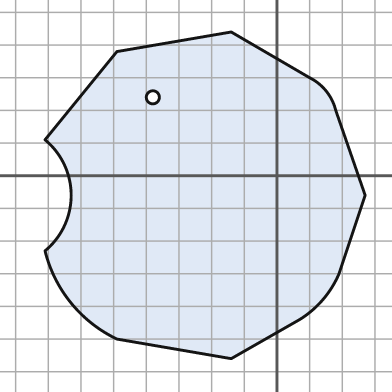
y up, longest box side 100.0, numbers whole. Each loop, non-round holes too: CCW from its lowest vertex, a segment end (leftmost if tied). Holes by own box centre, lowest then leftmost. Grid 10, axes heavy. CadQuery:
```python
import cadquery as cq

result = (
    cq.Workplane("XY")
    .moveTo(-14.0, -56.0)
    .lineTo(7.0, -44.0)
    .threePointArc((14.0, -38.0), (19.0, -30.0))
    .lineTo(27.0, -6.0)
    .lineTo(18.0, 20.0)
    .threePointArc((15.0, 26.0), (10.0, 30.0))
    .lineTo(-14.0, 44.0)
    .lineTo(-49.0, 38.0)
    .lineTo(-71.0, 11.0)
    .threePointArc((-63.0, -6.0), (-71.0, -23.0))
    .threePointArc((-63.0, -39.0), (-49.0, -50.0))
    .close()
    .moveTo(-38.0, 24.0)
    .circle(2.0)
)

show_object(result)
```